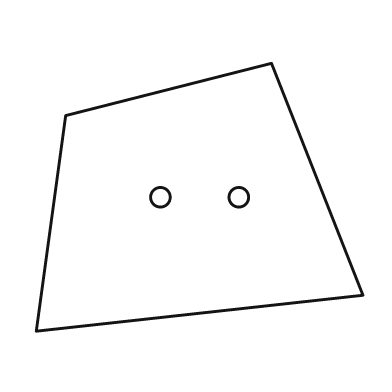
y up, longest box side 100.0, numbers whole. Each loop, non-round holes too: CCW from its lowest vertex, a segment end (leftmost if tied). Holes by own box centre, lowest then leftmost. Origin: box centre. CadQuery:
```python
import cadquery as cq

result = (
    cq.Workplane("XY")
    .moveTo(-50.0, -41.0)
    .lineTo(50.0, -30.0)
    .lineTo(22.0, 41.0)
    .lineTo(-41.0, 25.0)
    .close()
    .moveTo(-12.0, 0.0)
    .circle(3.0)
    .moveTo(12.0, 0.0)
    .circle(3.0)
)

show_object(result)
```